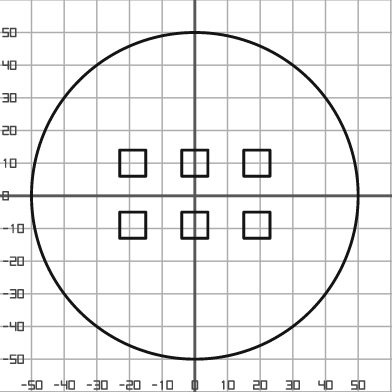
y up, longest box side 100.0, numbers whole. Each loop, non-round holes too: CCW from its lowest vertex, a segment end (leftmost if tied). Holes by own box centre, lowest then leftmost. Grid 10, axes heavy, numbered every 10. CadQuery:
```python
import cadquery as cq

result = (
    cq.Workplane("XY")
    .moveTo(0.0, 0.0)
    .circle(50.0)
    .moveTo(-23.0, -13.0)
    .lineTo(-15.0, -13.0)
    .lineTo(-15.0, -5.0)
    .lineTo(-23.0, -5.0)
    .close()
    .moveTo(-4.0, -13.0)
    .lineTo(4.0, -13.0)
    .lineTo(4.0, -5.0)
    .lineTo(-4.0, -5.0)
    .close()
    .moveTo(15.0, -13.0)
    .lineTo(23.0, -13.0)
    .lineTo(23.0, -5.0)
    .lineTo(15.0, -5.0)
    .close()
    .moveTo(-23.0, 6.0)
    .lineTo(-15.0, 6.0)
    .lineTo(-15.0, 14.0)
    .lineTo(-23.0, 14.0)
    .close()
    .moveTo(-4.0, 6.0)
    .lineTo(4.0, 6.0)
    .lineTo(4.0, 14.0)
    .lineTo(-4.0, 14.0)
    .close()
    .moveTo(15.0, 6.0)
    .lineTo(23.0, 6.0)
    .lineTo(23.0, 14.0)
    .lineTo(15.0, 14.0)
    .close()
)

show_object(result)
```